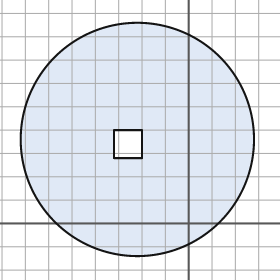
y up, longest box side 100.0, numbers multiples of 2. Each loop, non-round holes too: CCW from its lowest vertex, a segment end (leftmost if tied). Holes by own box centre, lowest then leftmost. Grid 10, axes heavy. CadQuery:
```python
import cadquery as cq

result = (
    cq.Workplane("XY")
    .moveTo(-22.0, 36.0)
    .circle(50.0)
    .moveTo(-32.0, 28.0)
    .lineTo(-20.0, 28.0)
    .lineTo(-20.0, 40.0)
    .lineTo(-32.0, 40.0)
    .close()
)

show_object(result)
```